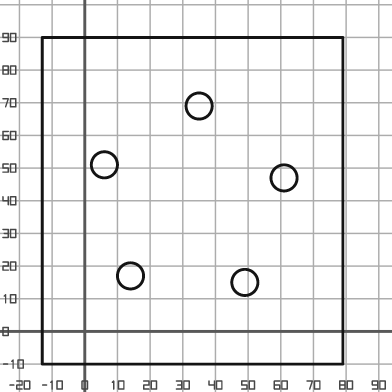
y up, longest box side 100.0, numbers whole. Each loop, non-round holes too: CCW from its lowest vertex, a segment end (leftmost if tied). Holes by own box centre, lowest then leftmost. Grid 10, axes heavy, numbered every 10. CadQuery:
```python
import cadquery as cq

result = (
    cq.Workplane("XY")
    .moveTo(-13.0, -10.0)
    .lineTo(79.0, -10.0)
    .lineTo(79.0, 90.0)
    .lineTo(-13.0, 90.0)
    .close()
    .moveTo(49.0, 15.0)
    .circle(4.0)
    .moveTo(14.0, 17.0)
    .circle(4.0)
    .moveTo(61.0, 47.0)
    .circle(4.0)
    .moveTo(6.0, 51.0)
    .circle(4.0)
    .moveTo(35.0, 69.0)
    .circle(4.0)
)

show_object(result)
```